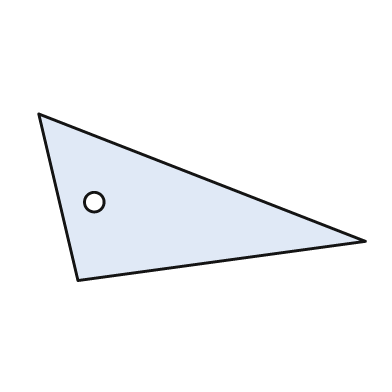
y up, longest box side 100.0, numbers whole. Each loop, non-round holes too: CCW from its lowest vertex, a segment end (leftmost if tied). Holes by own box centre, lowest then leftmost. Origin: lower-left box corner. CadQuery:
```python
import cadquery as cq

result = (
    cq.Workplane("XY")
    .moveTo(12.0, 0.0)
    .lineTo(100.0, 12.0)
    .lineTo(0.0, 51.0)
    .close()
    .moveTo(17.0, 24.0)
    .circle(3.0)
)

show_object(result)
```